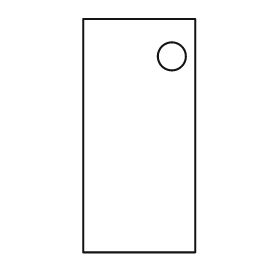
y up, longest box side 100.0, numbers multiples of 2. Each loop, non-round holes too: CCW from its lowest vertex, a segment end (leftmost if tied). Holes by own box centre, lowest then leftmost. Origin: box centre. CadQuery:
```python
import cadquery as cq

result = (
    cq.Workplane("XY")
    .moveTo(-24.0, -50.0)
    .lineTo(24.0, -50.0)
    .lineTo(24.0, 50.0)
    .lineTo(-24.0, 50.0)
    .close()
    .moveTo(14.0, 34.0)
    .circle(6.0)
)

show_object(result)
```